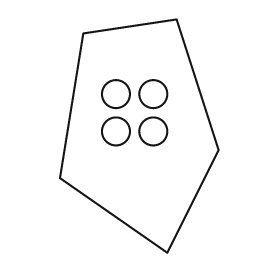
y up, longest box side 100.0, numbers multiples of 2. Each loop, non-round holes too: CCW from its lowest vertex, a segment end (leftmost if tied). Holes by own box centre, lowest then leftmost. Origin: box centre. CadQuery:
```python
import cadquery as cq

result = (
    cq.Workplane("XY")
    .moveTo(12.0, -50.0)
    .lineTo(34.0, -6.0)
    .lineTo(16.0, 50.0)
    .lineTo(-24.0, 44.0)
    .lineTo(-34.0, -18.0)
    .close()
    .moveTo(-10.0, 2.0)
    .circle(6.0)
    .moveTo(6.0, 2.0)
    .circle(6.0)
    .moveTo(-10.0, 18.0)
    .circle(6.0)
    .moveTo(6.0, 18.0)
    .circle(6.0)
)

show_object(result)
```